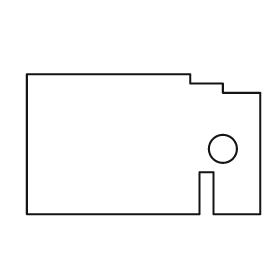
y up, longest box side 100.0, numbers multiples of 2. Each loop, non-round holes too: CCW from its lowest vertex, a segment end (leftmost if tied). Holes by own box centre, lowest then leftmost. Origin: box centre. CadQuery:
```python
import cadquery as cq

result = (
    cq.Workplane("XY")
    .moveTo(-50.0, -30.0)
    .lineTo(24.0, -30.0)
    .lineTo(24.0, -12.0)
    .lineTo(30.0, -12.0)
    .lineTo(30.0, -30.0)
    .lineTo(50.0, -30.0)
    .lineTo(50.0, 22.0)
    .lineTo(34.0, 22.0)
    .lineTo(34.0, 26.0)
    .lineTo(20.0, 26.0)
    .lineTo(20.0, 30.0)
    .lineTo(-50.0, 30.0)
    .close()
    .moveTo(34.0, -2.0)
    .circle(6.0)
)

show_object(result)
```